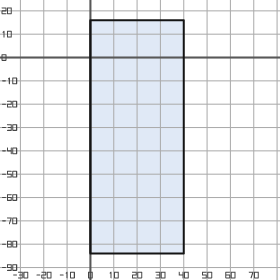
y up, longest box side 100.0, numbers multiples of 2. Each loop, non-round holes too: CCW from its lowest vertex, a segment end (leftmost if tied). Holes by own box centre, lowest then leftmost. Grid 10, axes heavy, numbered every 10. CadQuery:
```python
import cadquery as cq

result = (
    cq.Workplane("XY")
    .moveTo(0.0, -84.0)
    .lineTo(40.0, -84.0)
    .lineTo(40.0, 16.0)
    .lineTo(0.0, 16.0)
    .close()
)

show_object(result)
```